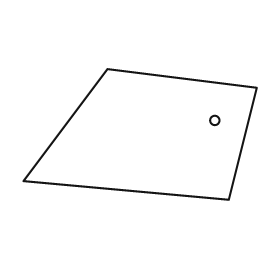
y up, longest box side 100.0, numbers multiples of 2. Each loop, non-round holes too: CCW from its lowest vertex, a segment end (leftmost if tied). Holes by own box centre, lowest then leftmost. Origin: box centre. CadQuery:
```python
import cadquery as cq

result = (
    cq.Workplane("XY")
    .moveTo(38.0, -28.0)
    .lineTo(50.0, 20.0)
    .lineTo(-14.0, 28.0)
    .lineTo(-50.0, -20.0)
    .close()
    .moveTo(32.0, 6.0)
    .circle(2.0)
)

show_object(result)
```